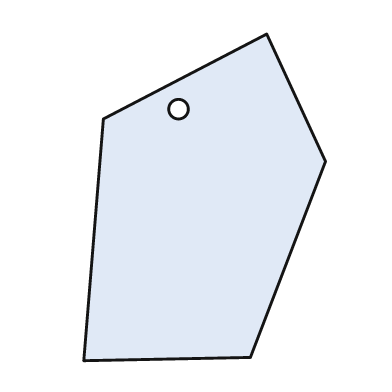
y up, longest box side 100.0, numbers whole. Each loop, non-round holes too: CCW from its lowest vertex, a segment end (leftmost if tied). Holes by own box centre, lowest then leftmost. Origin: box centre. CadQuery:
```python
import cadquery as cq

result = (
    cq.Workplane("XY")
    .moveTo(-37.0, -50.0)
    .lineTo(14.0, -49.0)
    .lineTo(37.0, 11.0)
    .lineTo(19.0, 50.0)
    .lineTo(-31.0, 24.0)
    .close()
    .moveTo(-8.0, 27.0)
    .circle(3.0)
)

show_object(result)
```